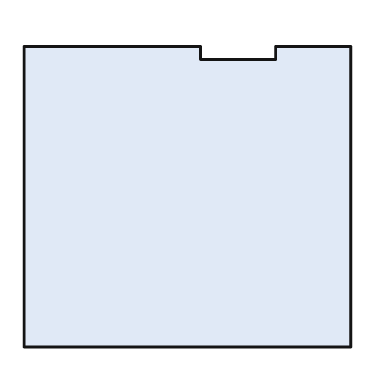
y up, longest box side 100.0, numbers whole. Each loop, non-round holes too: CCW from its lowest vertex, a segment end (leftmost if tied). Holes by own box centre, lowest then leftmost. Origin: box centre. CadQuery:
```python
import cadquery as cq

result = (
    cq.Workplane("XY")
    .moveTo(-50.0, -46.0)
    .lineTo(50.0, -46.0)
    .lineTo(50.0, 46.0)
    .lineTo(27.0, 46.0)
    .lineTo(27.0, 42.0)
    .lineTo(4.0, 42.0)
    .lineTo(4.0, 46.0)
    .lineTo(-50.0, 46.0)
    .close()
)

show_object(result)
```